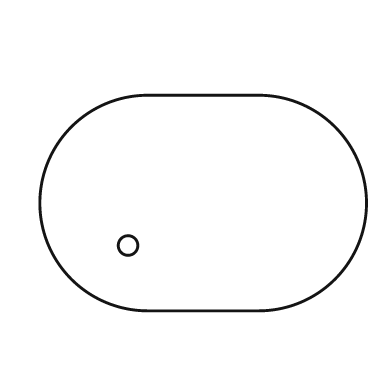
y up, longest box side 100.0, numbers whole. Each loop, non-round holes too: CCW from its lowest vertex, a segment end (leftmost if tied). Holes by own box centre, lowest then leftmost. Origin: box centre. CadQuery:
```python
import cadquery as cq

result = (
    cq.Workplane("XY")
    .moveTo(-17.0, -33.0)
    .lineTo(17.0, -33.0)
    .threePointArc((50.0, 0.0), (17.0, 33.0))
    .lineTo(-17.0, 33.0)
    .threePointArc((-50.0, 0.0), (-17.0, -33.0))
    .close()
    .moveTo(-23.0, -13.0)
    .circle(3.0)
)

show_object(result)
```